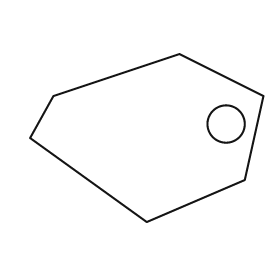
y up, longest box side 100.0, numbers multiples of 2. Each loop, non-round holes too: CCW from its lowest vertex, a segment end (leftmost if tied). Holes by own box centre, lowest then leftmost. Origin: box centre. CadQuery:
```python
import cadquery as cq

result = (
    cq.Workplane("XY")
    .moveTo(0.0, -36.0)
    .lineTo(42.0, -18.0)
    .lineTo(50.0, 18.0)
    .lineTo(14.0, 36.0)
    .lineTo(-40.0, 18.0)
    .lineTo(-50.0, 0.0)
    .close()
    .moveTo(34.0, 6.0)
    .circle(8.0)
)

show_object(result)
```